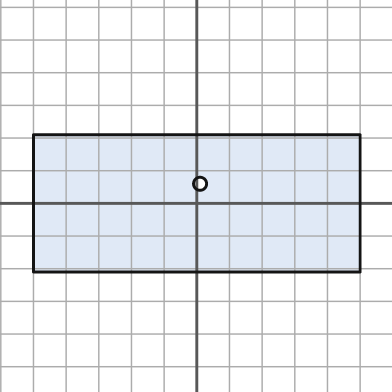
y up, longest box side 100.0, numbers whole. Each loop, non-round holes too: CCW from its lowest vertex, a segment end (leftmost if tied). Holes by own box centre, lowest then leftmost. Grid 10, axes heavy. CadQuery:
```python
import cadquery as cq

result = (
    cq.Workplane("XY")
    .moveTo(-50.0, -21.0)
    .lineTo(50.0, -21.0)
    .lineTo(50.0, 21.0)
    .lineTo(-50.0, 21.0)
    .close()
    .moveTo(1.0, 6.0)
    .circle(2.0)
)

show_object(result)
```